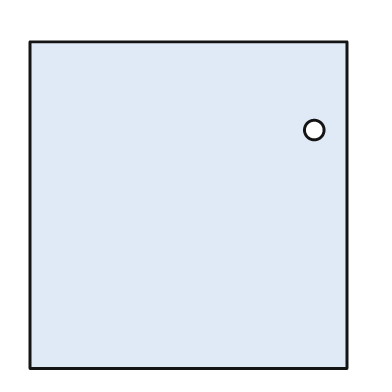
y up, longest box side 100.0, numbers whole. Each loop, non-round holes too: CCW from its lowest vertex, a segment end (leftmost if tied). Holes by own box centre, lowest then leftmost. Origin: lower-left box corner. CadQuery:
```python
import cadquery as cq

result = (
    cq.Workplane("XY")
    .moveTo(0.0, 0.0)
    .lineTo(97.0, 0.0)
    .lineTo(97.0, 100.0)
    .lineTo(0.0, 100.0)
    .close()
    .moveTo(87.0, 73.0)
    .circle(3.0)
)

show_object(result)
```